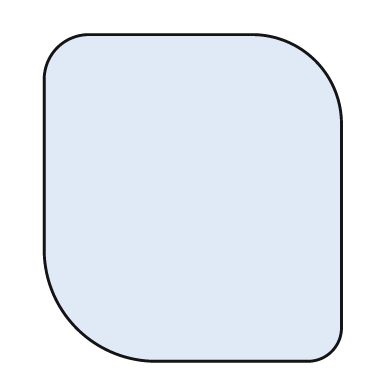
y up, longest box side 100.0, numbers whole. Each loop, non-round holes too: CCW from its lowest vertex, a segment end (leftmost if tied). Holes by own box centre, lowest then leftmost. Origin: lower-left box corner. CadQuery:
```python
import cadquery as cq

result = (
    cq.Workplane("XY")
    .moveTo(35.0, 0.0)
    .lineTo(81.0, 0.0)
    .threePointArc((88.0, 3.0), (91.0, 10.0))
    .lineTo(91.0, 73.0)
    .threePointArc((83.0, 92.0), (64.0, 100.0))
    .lineTo(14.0, 100.0)
    .threePointArc((4.0, 96.0), (0.0, 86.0))
    .lineTo(0.0, 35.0)
    .threePointArc((10.0, 10.0), (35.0, 0.0))
    .close()
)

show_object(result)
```